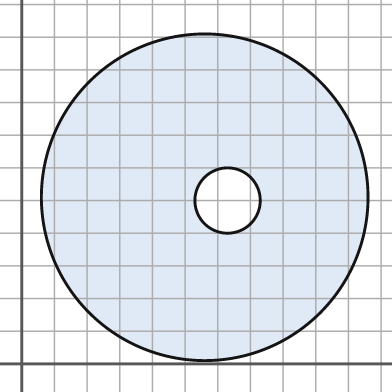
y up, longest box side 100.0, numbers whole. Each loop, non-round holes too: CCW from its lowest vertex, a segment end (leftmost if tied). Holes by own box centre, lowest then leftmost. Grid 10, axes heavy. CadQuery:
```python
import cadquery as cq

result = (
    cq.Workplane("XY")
    .moveTo(56.0, 51.0)
    .circle(50.0)
    .moveTo(63.0, 50.0)
    .circle(10.0)
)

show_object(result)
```